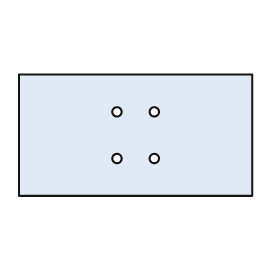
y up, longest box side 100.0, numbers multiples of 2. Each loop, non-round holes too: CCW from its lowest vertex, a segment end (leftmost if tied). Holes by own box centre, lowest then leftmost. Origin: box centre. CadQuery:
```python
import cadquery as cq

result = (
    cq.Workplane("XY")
    .moveTo(-50.0, -26.0)
    .lineTo(50.0, -26.0)
    .lineTo(50.0, 26.0)
    .lineTo(-50.0, 26.0)
    .close()
    .moveTo(-8.0, -10.0)
    .circle(2.0)
    .moveTo(8.0, -10.0)
    .circle(2.0)
    .moveTo(-8.0, 10.0)
    .circle(2.0)
    .moveTo(8.0, 10.0)
    .circle(2.0)
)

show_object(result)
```